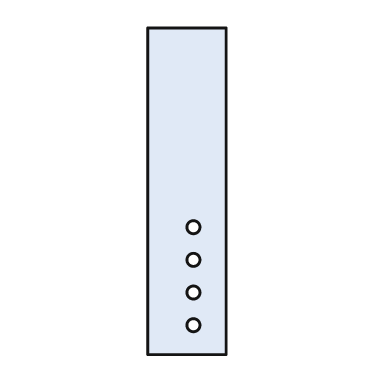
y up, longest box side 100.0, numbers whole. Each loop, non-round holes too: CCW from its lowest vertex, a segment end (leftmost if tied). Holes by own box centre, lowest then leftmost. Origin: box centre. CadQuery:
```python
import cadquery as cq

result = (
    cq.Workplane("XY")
    .moveTo(-12.0, -50.0)
    .lineTo(12.0, -50.0)
    .lineTo(12.0, 50.0)
    .lineTo(-12.0, 50.0)
    .close()
    .moveTo(2.0, -41.0)
    .circle(2.0)
    .moveTo(2.0, -31.0)
    .circle(2.0)
    .moveTo(2.0, -21.0)
    .circle(2.0)
    .moveTo(2.0, -11.0)
    .circle(2.0)
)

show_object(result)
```